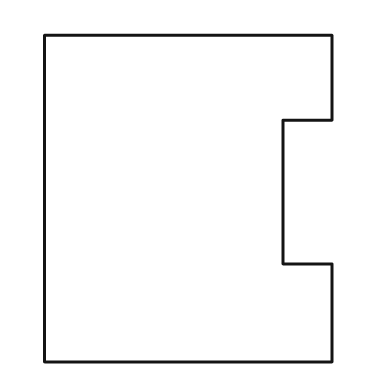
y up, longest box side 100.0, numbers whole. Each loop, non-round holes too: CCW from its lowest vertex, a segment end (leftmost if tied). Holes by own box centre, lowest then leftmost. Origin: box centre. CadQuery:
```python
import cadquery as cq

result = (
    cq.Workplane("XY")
    .moveTo(-44.0, -50.0)
    .lineTo(44.0, -50.0)
    .lineTo(44.0, -20.0)
    .lineTo(29.0, -20.0)
    .lineTo(29.0, 24.0)
    .lineTo(44.0, 24.0)
    .lineTo(44.0, 50.0)
    .lineTo(-44.0, 50.0)
    .close()
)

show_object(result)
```